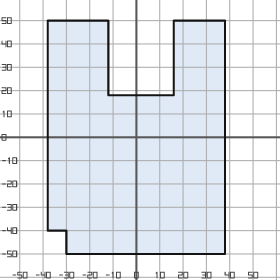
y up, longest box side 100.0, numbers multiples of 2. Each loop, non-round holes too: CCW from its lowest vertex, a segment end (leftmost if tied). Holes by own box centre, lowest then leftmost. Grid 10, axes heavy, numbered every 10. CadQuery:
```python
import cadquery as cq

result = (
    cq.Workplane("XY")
    .moveTo(-30.0, -50.0)
    .lineTo(38.0, -50.0)
    .lineTo(38.0, 50.0)
    .lineTo(16.0, 50.0)
    .lineTo(16.0, 18.0)
    .lineTo(-12.0, 18.0)
    .lineTo(-12.0, 50.0)
    .lineTo(-38.0, 50.0)
    .lineTo(-38.0, -40.0)
    .lineTo(-30.0, -40.0)
    .close()
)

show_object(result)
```